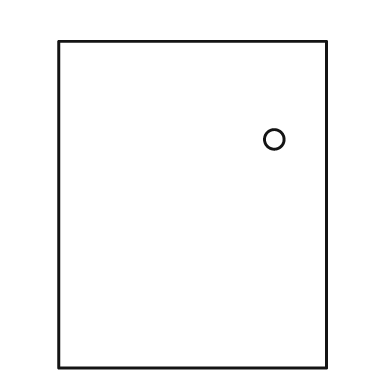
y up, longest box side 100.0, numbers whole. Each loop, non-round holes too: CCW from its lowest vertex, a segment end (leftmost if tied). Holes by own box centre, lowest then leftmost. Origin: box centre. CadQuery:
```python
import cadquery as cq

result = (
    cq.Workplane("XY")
    .moveTo(-41.0, -50.0)
    .lineTo(41.0, -50.0)
    .lineTo(41.0, 50.0)
    .lineTo(-41.0, 50.0)
    .close()
    .moveTo(25.0, 20.0)
    .circle(3.0)
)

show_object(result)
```